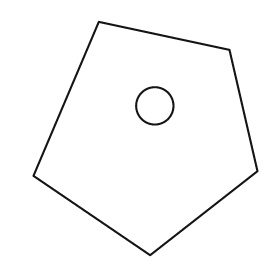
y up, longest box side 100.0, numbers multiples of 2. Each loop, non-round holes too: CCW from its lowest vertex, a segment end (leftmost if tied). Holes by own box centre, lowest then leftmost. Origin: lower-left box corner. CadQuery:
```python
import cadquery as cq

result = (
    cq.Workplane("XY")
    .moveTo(50.0, 0.0)
    .lineTo(96.0, 36.0)
    .lineTo(84.0, 88.0)
    .lineTo(28.0, 100.0)
    .lineTo(0.0, 34.0)
    .close()
    .moveTo(52.0, 64.0)
    .circle(8.0)
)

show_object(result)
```